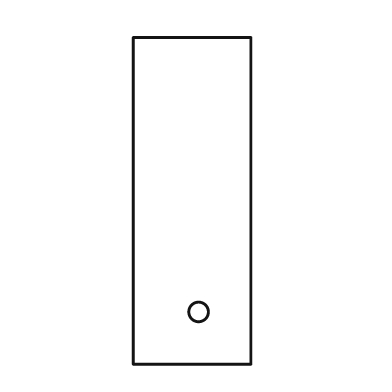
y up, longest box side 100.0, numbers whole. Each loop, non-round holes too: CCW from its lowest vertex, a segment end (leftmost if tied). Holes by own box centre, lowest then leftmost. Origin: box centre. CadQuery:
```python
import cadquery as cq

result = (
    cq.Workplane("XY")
    .moveTo(-18.0, -50.0)
    .lineTo(18.0, -50.0)
    .lineTo(18.0, 50.0)
    .lineTo(-18.0, 50.0)
    .close()
    .moveTo(2.0, -34.0)
    .circle(3.0)
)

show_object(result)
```